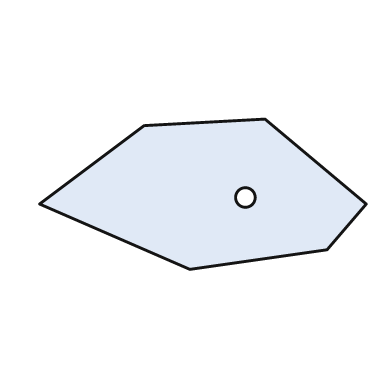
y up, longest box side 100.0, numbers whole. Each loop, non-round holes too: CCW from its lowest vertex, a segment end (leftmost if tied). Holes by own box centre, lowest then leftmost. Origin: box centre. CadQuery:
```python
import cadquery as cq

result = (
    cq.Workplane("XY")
    .moveTo(-4.0, -23.0)
    .lineTo(38.0, -17.0)
    .lineTo(50.0, -3.0)
    .lineTo(19.0, 23.0)
    .lineTo(-18.0, 21.0)
    .lineTo(-50.0, -3.0)
    .close()
    .moveTo(13.0, -1.0)
    .circle(3.0)
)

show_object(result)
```